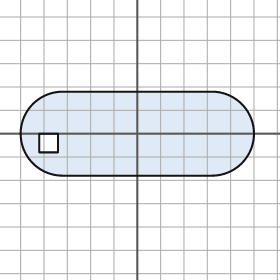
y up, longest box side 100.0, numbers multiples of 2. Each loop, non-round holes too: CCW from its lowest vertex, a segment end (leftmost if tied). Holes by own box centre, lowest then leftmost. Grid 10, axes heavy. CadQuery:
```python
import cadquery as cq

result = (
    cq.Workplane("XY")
    .moveTo(-32.0, -18.0)
    .lineTo(32.0, -18.0)
    .threePointArc((50.0, 0.0), (32.0, 18.0))
    .lineTo(-32.0, 18.0)
    .threePointArc((-50.0, 0.0), (-32.0, -18.0))
    .close()
    .moveTo(-42.0, -8.0)
    .lineTo(-34.0, -8.0)
    .lineTo(-34.0, 0.0)
    .lineTo(-42.0, 0.0)
    .close()
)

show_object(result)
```